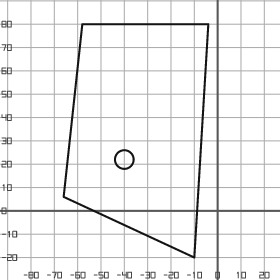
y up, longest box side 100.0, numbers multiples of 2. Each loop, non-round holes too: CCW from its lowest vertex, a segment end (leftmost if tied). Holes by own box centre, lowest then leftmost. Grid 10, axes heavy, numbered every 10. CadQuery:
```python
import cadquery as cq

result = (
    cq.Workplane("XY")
    .moveTo(-10.0, -20.0)
    .lineTo(-4.0, 80.0)
    .lineTo(-58.0, 80.0)
    .lineTo(-66.0, 6.0)
    .close()
    .moveTo(-40.0, 22.0)
    .circle(4.0)
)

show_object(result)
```